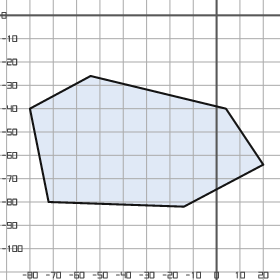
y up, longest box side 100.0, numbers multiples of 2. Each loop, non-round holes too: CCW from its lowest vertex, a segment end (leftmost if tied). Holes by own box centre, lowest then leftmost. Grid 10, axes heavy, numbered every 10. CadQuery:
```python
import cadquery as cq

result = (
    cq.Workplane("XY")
    .moveTo(-14.0, -82.0)
    .lineTo(20.0, -64.0)
    .lineTo(4.0, -40.0)
    .lineTo(-54.0, -26.0)
    .lineTo(-80.0, -40.0)
    .lineTo(-72.0, -80.0)
    .close()
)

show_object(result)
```